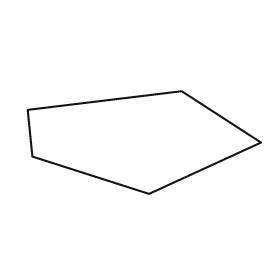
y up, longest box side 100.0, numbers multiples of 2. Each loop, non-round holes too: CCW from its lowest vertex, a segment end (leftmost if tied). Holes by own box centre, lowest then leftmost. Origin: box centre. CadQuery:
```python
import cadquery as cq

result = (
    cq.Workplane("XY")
    .moveTo(2.0, -22.0)
    .lineTo(50.0, 0.0)
    .lineTo(16.0, 22.0)
    .lineTo(-50.0, 14.0)
    .lineTo(-48.0, -6.0)
    .close()
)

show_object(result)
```